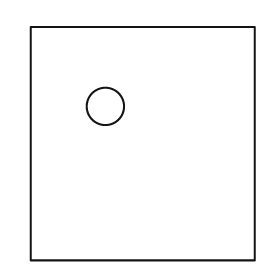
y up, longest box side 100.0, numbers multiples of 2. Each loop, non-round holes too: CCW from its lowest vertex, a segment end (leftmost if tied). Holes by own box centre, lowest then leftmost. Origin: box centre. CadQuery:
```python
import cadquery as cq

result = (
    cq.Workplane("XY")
    .moveTo(-48.0, -50.0)
    .lineTo(48.0, -50.0)
    .lineTo(48.0, 50.0)
    .lineTo(-48.0, 50.0)
    .close()
    .moveTo(-16.0, 16.0)
    .circle(8.0)
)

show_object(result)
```